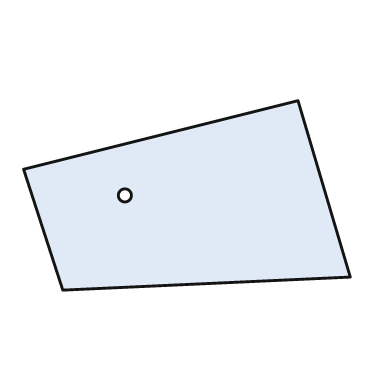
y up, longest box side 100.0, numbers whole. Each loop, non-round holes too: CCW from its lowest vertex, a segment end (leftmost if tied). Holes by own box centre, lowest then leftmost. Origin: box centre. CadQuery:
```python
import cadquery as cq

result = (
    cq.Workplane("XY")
    .moveTo(-38.0, -29.0)
    .lineTo(50.0, -25.0)
    .lineTo(34.0, 29.0)
    .lineTo(-50.0, 8.0)
    .close()
    .moveTo(-19.0, 0.0)
    .circle(2.0)
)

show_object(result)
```